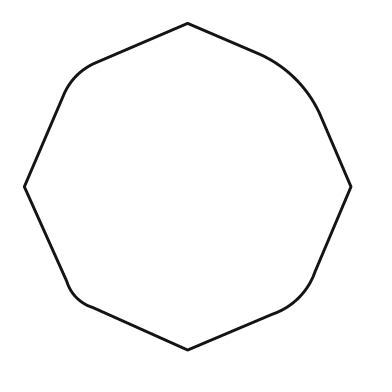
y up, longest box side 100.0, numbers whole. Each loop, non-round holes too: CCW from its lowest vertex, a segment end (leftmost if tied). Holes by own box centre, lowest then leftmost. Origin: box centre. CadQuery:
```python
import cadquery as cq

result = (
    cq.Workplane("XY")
    .moveTo(0.0, -50.0)
    .lineTo(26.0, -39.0)
    .threePointArc((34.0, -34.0), (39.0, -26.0))
    .lineTo(50.0, 0.0)
    .lineTo(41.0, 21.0)
    .threePointArc((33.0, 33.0), (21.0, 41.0))
    .lineTo(0.0, 50.0)
    .lineTo(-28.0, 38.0)
    .threePointArc((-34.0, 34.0), (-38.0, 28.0))
    .lineTo(-50.0, 0.0)
    .lineTo(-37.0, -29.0)
    .threePointArc((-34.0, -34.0), (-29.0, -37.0))
    .close()
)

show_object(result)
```